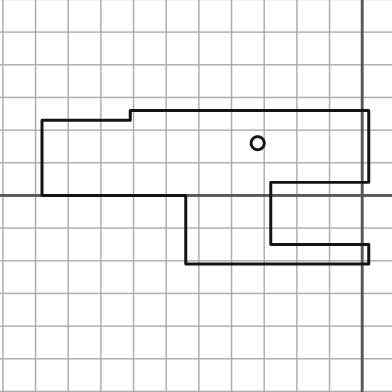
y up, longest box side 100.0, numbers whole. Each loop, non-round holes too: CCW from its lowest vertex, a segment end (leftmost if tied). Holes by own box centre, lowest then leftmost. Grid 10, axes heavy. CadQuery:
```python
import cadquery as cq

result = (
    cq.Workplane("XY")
    .moveTo(-54.0, -21.0)
    .lineTo(2.0, -21.0)
    .lineTo(2.0, -15.0)
    .lineTo(-28.0, -15.0)
    .lineTo(-28.0, 4.0)
    .lineTo(2.0, 4.0)
    .lineTo(2.0, 26.0)
    .lineTo(-71.0, 26.0)
    .lineTo(-71.0, 23.0)
    .lineTo(-98.0, 23.0)
    .lineTo(-98.0, 0.0)
    .lineTo(-54.0, 0.0)
    .close()
    .moveTo(-32.0, 16.0)
    .circle(2.0)
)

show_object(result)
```